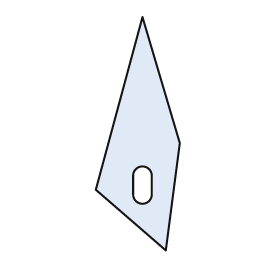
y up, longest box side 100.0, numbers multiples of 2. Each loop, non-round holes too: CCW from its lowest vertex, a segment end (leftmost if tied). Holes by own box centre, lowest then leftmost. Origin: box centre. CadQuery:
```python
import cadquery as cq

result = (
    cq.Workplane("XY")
    .moveTo(12.0, -50.0)
    .lineTo(18.0, -4.0)
    .lineTo(2.0, 50.0)
    .lineTo(-18.0, -24.0)
    .close()
    .moveTo(-2.0, -26.0)
    .threePointArc((2.0, -30.0), (6.0, -26.0))
    .lineTo(6.0, -18.0)
    .threePointArc((2.0, -14.0), (-2.0, -18.0))
    .close()
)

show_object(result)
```